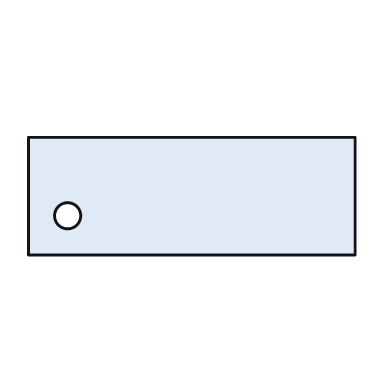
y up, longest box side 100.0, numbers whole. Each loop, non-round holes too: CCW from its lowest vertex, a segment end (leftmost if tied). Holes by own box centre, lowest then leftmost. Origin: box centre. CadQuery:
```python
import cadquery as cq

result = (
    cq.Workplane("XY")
    .moveTo(-50.0, -18.0)
    .lineTo(50.0, -18.0)
    .lineTo(50.0, 18.0)
    .lineTo(-50.0, 18.0)
    .close()
    .moveTo(-38.0, -6.0)
    .circle(4.0)
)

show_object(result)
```